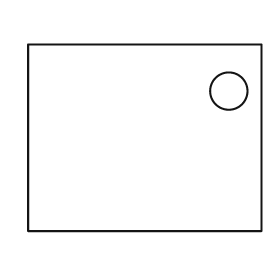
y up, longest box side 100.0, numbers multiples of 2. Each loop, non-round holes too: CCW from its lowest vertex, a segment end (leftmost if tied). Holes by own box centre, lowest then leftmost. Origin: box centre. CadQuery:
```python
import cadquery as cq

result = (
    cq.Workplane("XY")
    .moveTo(-50.0, -40.0)
    .lineTo(50.0, -40.0)
    .lineTo(50.0, 40.0)
    .lineTo(-50.0, 40.0)
    .close()
    .moveTo(36.0, 20.0)
    .circle(8.0)
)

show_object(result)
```